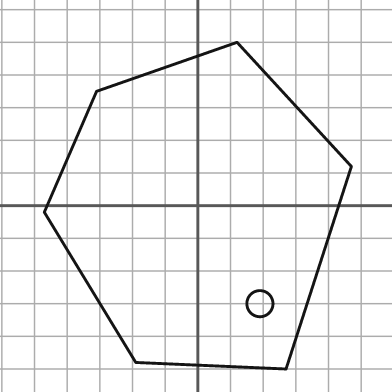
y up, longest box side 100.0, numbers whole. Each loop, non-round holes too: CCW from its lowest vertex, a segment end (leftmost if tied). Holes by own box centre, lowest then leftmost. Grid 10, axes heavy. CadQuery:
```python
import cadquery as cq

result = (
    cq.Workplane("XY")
    .moveTo(27.0, -50.0)
    .lineTo(47.0, 12.0)
    .lineTo(12.0, 50.0)
    .lineTo(-31.0, 35.0)
    .lineTo(-47.0, -2.0)
    .lineTo(-19.0, -48.0)
    .close()
    .moveTo(19.0, -30.0)
    .circle(4.0)
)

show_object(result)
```